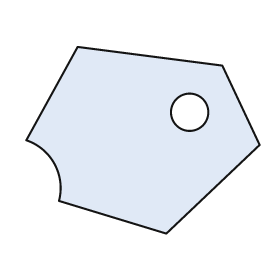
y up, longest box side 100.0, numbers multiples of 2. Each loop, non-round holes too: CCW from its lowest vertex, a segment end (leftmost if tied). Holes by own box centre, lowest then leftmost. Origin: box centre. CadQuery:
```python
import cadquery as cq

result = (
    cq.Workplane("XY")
    .moveTo(10.0, -40.0)
    .lineTo(50.0, -2.0)
    .lineTo(34.0, 32.0)
    .lineTo(-28.0, 40.0)
    .lineTo(-50.0, 0.0)
    .threePointArc((-38.0, -10.0), (-36.0, -26.0))
    .close()
    .moveTo(20.0, 12.0)
    .circle(8.0)
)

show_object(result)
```